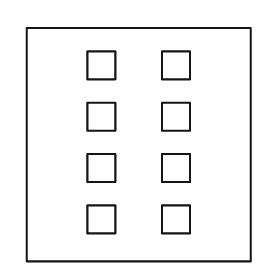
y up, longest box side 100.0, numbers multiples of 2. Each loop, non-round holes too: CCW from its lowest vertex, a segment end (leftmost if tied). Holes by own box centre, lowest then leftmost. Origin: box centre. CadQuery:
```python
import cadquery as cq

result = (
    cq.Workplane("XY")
    .moveTo(-48.0, -50.0)
    .lineTo(48.0, -50.0)
    .lineTo(48.0, 50.0)
    .lineTo(-48.0, 50.0)
    .close()
    .moveTo(-22.0, -38.0)
    .lineTo(-10.0, -38.0)
    .lineTo(-10.0, -26.0)
    .lineTo(-22.0, -26.0)
    .close()
    .moveTo(10.0, -38.0)
    .lineTo(22.0, -38.0)
    .lineTo(22.0, -26.0)
    .lineTo(10.0, -26.0)
    .close()
    .moveTo(-22.0, -16.0)
    .lineTo(-10.0, -16.0)
    .lineTo(-10.0, -4.0)
    .lineTo(-22.0, -4.0)
    .close()
    .moveTo(10.0, -16.0)
    .lineTo(22.0, -16.0)
    .lineTo(22.0, -4.0)
    .lineTo(10.0, -4.0)
    .close()
    .moveTo(-22.0, 6.0)
    .lineTo(-10.0, 6.0)
    .lineTo(-10.0, 18.0)
    .lineTo(-22.0, 18.0)
    .close()
    .moveTo(10.0, 6.0)
    .lineTo(22.0, 6.0)
    .lineTo(22.0, 18.0)
    .lineTo(10.0, 18.0)
    .close()
    .moveTo(-22.0, 28.0)
    .lineTo(-10.0, 28.0)
    .lineTo(-10.0, 40.0)
    .lineTo(-22.0, 40.0)
    .close()
    .moveTo(10.0, 28.0)
    .lineTo(22.0, 28.0)
    .lineTo(22.0, 40.0)
    .lineTo(10.0, 40.0)
    .close()
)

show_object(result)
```